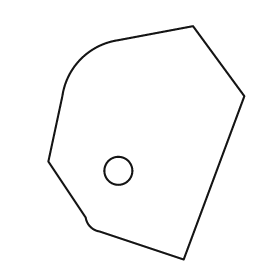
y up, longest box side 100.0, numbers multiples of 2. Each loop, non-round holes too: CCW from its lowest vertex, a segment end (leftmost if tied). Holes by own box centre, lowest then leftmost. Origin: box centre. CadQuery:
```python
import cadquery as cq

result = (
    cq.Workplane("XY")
    .moveTo(16.0, -50.0)
    .lineTo(42.0, 20.0)
    .lineTo(20.0, 50.0)
    .lineTo(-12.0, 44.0)
    .threePointArc((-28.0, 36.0), (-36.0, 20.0))
    .lineTo(-42.0, -8.0)
    .lineTo(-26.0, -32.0)
    .threePointArc((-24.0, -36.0), (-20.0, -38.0))
    .close()
    .moveTo(-12.0, -12.0)
    .circle(6.0)
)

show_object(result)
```